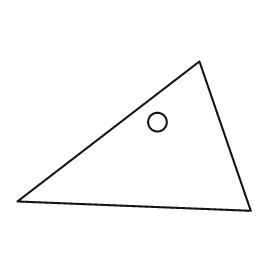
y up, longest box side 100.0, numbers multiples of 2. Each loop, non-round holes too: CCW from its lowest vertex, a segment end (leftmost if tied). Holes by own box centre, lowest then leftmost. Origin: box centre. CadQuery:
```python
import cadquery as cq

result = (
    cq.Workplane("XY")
    .moveTo(50.0, -32.0)
    .lineTo(28.0, 32.0)
    .lineTo(-50.0, -28.0)
    .close()
    .moveTo(10.0, 6.0)
    .circle(4.0)
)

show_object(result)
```